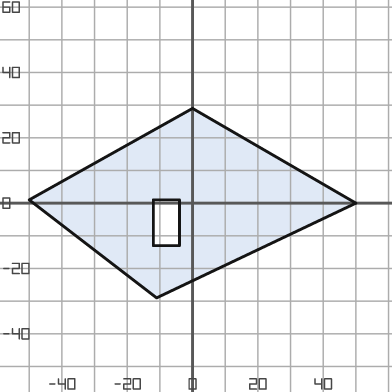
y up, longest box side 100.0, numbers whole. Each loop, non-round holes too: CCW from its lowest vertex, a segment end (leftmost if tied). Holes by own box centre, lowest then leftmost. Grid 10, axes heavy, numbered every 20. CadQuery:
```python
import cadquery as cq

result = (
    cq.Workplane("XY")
    .moveTo(-11.0, -29.0)
    .lineTo(50.0, 0.0)
    .lineTo(0.0, 29.0)
    .lineTo(-50.0, 1.0)
    .close()
    .moveTo(-12.0, -13.0)
    .lineTo(-4.0, -13.0)
    .lineTo(-4.0, 1.0)
    .lineTo(-12.0, 1.0)
    .close()
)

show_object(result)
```